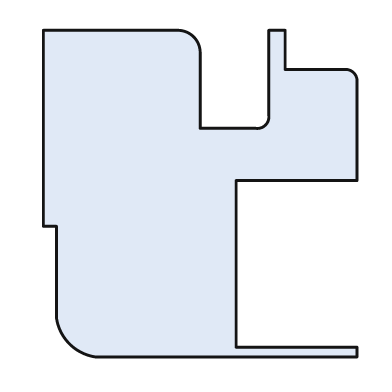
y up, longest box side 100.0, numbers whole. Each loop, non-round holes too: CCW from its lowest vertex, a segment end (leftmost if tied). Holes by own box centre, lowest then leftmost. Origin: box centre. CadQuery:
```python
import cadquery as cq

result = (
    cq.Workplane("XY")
    .moveTo(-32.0, -50.0)
    .lineTo(48.0, -50.0)
    .lineTo(48.0, -47.0)
    .lineTo(11.0, -47.0)
    .lineTo(11.0, 4.0)
    .lineTo(48.0, 4.0)
    .lineTo(48.0, 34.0)
    .threePointArc((47.0, 37.0), (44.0, 38.0))
    .lineTo(26.0, 38.0)
    .lineTo(26.0, 50.0)
    .lineTo(21.0, 50.0)
    .lineTo(21.0, 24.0)
    .threePointArc((20.0, 21.0), (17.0, 20.0))
    .lineTo(0.0, 20.0)
    .lineTo(0.0, 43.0)
    .threePointArc((-2.0, 48.0), (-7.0, 50.0))
    .lineTo(-48.0, 50.0)
    .lineTo(-48.0, -10.0)
    .lineTo(-44.0, -10.0)
    .lineTo(-44.0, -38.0)
    .threePointArc((-40.0, -46.0), (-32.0, -50.0))
    .close()
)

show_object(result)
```